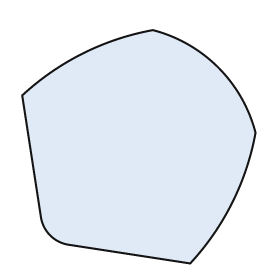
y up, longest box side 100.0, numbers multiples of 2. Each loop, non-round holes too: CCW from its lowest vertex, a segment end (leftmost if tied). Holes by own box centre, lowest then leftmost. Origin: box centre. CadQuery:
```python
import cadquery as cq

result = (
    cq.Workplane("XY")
    .moveTo(22.0, -50.0)
    .threePointArc((40.0, -24.0), (50.0, 6.0))
    .threePointArc((34.0, 34.0), (6.0, 50.0))
    .threePointArc((-24.0, 40.0), (-50.0, 22.0))
    .lineTo(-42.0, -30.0)
    .threePointArc((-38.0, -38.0), (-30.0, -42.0))
    .close()
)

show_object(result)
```